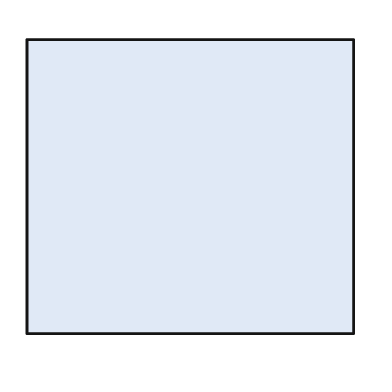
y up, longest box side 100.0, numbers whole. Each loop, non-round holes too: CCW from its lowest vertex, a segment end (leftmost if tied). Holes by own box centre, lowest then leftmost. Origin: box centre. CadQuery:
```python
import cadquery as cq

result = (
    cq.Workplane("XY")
    .moveTo(-50.0, -45.0)
    .lineTo(50.0, -45.0)
    .lineTo(50.0, 45.0)
    .lineTo(-50.0, 45.0)
    .close()
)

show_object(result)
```